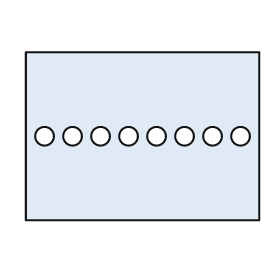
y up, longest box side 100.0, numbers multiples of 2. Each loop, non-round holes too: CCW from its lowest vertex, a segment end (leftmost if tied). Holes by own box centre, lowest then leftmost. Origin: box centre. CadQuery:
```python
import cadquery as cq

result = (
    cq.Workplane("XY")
    .moveTo(-50.0, -36.0)
    .lineTo(50.0, -36.0)
    .lineTo(50.0, 36.0)
    .lineTo(-50.0, 36.0)
    .close()
    .moveTo(-42.0, 0.0)
    .circle(4.0)
    .moveTo(-30.0, 0.0)
    .circle(4.0)
    .moveTo(-18.0, 0.0)
    .circle(4.0)
    .moveTo(-6.0, 0.0)
    .circle(4.0)
    .moveTo(6.0, 0.0)
    .circle(4.0)
    .moveTo(18.0, 0.0)
    .circle(4.0)
    .moveTo(30.0, 0.0)
    .circle(4.0)
    .moveTo(42.0, 0.0)
    .circle(4.0)
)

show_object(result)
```